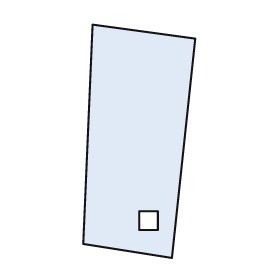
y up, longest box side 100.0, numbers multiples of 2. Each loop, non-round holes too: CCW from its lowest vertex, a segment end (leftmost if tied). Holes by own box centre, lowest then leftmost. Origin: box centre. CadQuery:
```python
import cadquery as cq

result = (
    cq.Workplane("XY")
    .moveTo(14.0, -50.0)
    .lineTo(24.0, 44.0)
    .lineTo(-20.0, 50.0)
    .lineTo(-24.0, -44.0)
    .close()
    .moveTo(0.0, -38.0)
    .lineTo(8.0, -38.0)
    .lineTo(8.0, -30.0)
    .lineTo(0.0, -30.0)
    .close()
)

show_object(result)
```